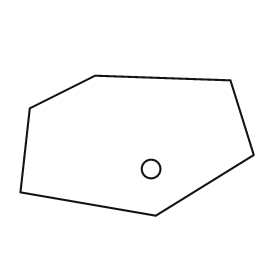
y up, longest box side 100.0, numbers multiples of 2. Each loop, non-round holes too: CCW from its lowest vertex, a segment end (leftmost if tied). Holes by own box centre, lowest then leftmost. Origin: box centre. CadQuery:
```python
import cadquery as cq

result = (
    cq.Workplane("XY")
    .moveTo(8.0, -30.0)
    .lineTo(50.0, -4.0)
    .lineTo(40.0, 28.0)
    .lineTo(-18.0, 30.0)
    .lineTo(-46.0, 16.0)
    .lineTo(-50.0, -20.0)
    .close()
    .moveTo(6.0, -10.0)
    .circle(4.0)
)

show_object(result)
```